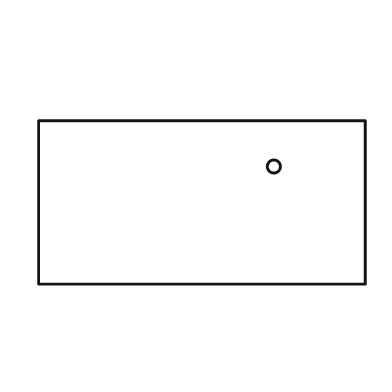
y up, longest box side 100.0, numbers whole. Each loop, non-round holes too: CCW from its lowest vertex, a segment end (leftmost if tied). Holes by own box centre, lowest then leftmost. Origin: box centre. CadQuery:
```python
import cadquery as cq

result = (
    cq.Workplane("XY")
    .moveTo(-50.0, -25.0)
    .lineTo(50.0, -25.0)
    .lineTo(50.0, 25.0)
    .lineTo(-50.0, 25.0)
    .close()
    .moveTo(22.0, 11.0)
    .circle(2.0)
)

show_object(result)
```